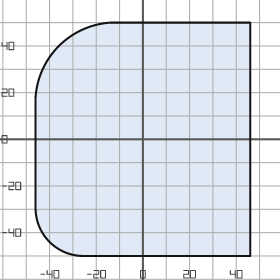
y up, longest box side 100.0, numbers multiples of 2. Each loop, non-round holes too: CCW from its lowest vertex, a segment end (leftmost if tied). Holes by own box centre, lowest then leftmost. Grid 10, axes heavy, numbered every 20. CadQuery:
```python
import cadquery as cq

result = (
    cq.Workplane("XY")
    .moveTo(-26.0, -50.0)
    .lineTo(46.0, -50.0)
    .lineTo(46.0, 50.0)
    .lineTo(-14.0, 50.0)
    .threePointArc((-36.0, 40.0), (-46.0, 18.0))
    .lineTo(-46.0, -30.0)
    .threePointArc((-40.0, -44.0), (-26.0, -50.0))
    .close()
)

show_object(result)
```